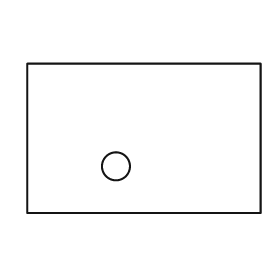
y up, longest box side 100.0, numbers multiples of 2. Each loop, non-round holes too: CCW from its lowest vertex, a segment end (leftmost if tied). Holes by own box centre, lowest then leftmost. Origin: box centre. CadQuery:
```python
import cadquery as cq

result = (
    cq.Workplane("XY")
    .moveTo(-50.0, -32.0)
    .lineTo(50.0, -32.0)
    .lineTo(50.0, 32.0)
    .lineTo(-50.0, 32.0)
    .close()
    .moveTo(-12.0, -12.0)
    .circle(6.0)
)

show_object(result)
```